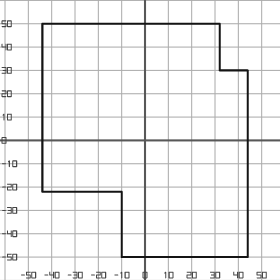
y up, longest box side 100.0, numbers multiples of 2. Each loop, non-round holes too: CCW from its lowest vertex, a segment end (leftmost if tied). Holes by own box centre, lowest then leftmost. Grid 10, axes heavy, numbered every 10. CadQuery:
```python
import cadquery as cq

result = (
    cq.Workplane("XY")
    .moveTo(-10.0, -50.0)
    .lineTo(44.0, -50.0)
    .lineTo(44.0, 30.0)
    .lineTo(32.0, 30.0)
    .lineTo(32.0, 50.0)
    .lineTo(-44.0, 50.0)
    .lineTo(-44.0, -22.0)
    .lineTo(-10.0, -22.0)
    .close()
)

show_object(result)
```